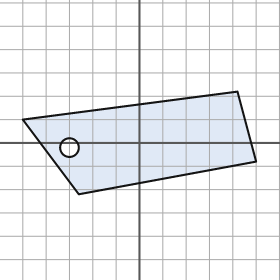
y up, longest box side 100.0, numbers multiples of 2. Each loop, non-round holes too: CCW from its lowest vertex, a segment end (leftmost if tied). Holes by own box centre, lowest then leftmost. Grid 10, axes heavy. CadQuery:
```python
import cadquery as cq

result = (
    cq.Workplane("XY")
    .moveTo(-26.0, -22.0)
    .lineTo(50.0, -8.0)
    .lineTo(42.0, 22.0)
    .lineTo(-50.0, 10.0)
    .close()
    .moveTo(-30.0, -2.0)
    .circle(4.0)
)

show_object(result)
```